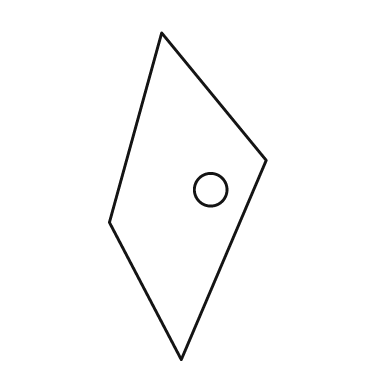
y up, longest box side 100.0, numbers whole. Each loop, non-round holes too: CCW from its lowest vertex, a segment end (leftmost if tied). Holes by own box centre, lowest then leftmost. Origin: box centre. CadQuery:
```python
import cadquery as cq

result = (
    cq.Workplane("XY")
    .moveTo(-2.0, -50.0)
    .lineTo(24.0, 11.0)
    .lineTo(-8.0, 50.0)
    .lineTo(-24.0, -8.0)
    .close()
    .moveTo(7.0, 2.0)
    .circle(5.0)
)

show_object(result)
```